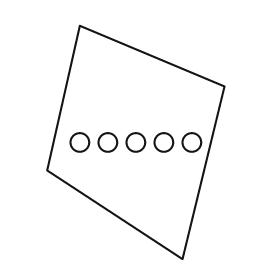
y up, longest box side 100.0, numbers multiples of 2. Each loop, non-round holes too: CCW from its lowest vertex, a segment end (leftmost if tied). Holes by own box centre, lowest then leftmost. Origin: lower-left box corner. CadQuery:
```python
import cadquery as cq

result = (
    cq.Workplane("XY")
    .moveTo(58.0, 0.0)
    .lineTo(76.0, 74.0)
    .lineTo(14.0, 100.0)
    .lineTo(0.0, 38.0)
    .close()
    .moveTo(14.0, 50.0)
    .circle(4.0)
    .moveTo(26.0, 50.0)
    .circle(4.0)
    .moveTo(38.0, 50.0)
    .circle(4.0)
    .moveTo(50.0, 50.0)
    .circle(4.0)
    .moveTo(62.0, 50.0)
    .circle(4.0)
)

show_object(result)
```